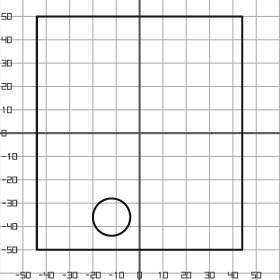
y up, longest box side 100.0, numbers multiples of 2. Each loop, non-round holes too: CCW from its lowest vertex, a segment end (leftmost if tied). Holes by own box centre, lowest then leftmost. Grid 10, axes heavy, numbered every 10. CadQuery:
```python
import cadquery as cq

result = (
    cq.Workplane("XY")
    .moveTo(-44.0, -50.0)
    .lineTo(44.0, -50.0)
    .lineTo(44.0, 50.0)
    .lineTo(-44.0, 50.0)
    .close()
    .moveTo(-12.0, -36.0)
    .circle(8.0)
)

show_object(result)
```